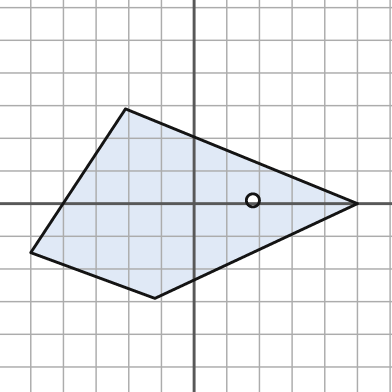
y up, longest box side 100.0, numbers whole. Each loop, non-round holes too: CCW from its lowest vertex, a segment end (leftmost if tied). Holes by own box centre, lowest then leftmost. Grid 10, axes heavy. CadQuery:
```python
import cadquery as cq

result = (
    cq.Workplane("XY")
    .moveTo(-12.0, -29.0)
    .lineTo(50.0, 0.0)
    .lineTo(-21.0, 29.0)
    .lineTo(-50.0, -15.0)
    .close()
    .moveTo(18.0, 1.0)
    .circle(2.0)
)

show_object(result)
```